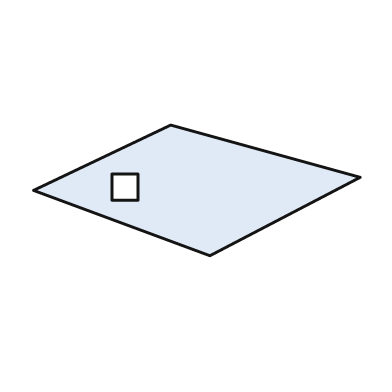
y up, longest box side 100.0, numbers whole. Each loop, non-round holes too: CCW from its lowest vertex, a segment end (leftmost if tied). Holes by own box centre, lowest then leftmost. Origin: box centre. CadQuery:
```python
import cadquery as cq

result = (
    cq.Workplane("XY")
    .moveTo(4.0, -20.0)
    .lineTo(50.0, 4.0)
    .lineTo(-8.0, 20.0)
    .lineTo(-50.0, 0.0)
    .close()
    .moveTo(-26.0, -3.0)
    .lineTo(-18.0, -3.0)
    .lineTo(-18.0, 5.0)
    .lineTo(-26.0, 5.0)
    .close()
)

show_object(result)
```